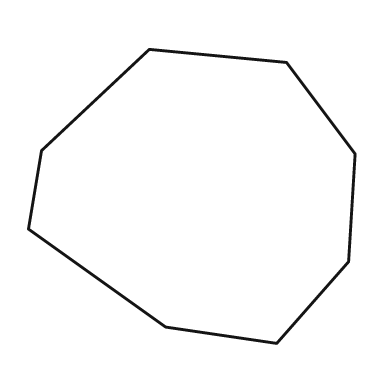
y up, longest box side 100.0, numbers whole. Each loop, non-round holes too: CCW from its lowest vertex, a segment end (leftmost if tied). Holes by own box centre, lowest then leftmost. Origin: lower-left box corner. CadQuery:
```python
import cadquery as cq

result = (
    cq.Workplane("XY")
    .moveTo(76.0, 0.0)
    .lineTo(98.0, 25.0)
    .lineTo(100.0, 58.0)
    .lineTo(79.0, 86.0)
    .lineTo(37.0, 90.0)
    .lineTo(4.0, 59.0)
    .lineTo(0.0, 35.0)
    .lineTo(42.0, 5.0)
    .close()
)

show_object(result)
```